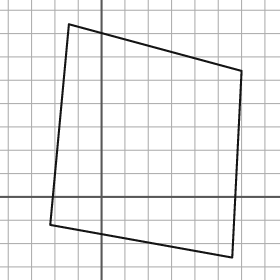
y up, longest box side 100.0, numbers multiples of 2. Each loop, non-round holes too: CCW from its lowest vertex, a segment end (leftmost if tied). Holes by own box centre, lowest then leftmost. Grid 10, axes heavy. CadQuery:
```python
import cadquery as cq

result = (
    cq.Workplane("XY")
    .moveTo(56.0, -26.0)
    .lineTo(60.0, 54.0)
    .lineTo(-14.0, 74.0)
    .lineTo(-22.0, -12.0)
    .close()
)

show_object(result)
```